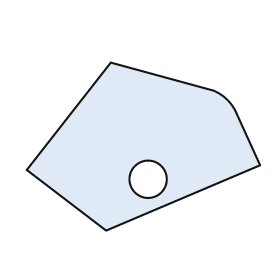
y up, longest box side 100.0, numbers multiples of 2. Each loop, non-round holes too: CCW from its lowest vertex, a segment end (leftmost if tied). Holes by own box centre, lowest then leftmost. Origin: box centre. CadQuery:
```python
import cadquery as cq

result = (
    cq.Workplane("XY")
    .moveTo(-16.0, -36.0)
    .lineTo(50.0, -8.0)
    .lineTo(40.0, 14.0)
    .threePointArc((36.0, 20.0), (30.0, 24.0))
    .lineTo(-14.0, 36.0)
    .lineTo(-50.0, -10.0)
    .close()
    .moveTo(2.0, -14.0)
    .circle(8.0)
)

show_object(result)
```